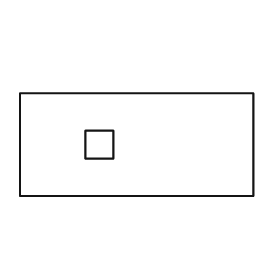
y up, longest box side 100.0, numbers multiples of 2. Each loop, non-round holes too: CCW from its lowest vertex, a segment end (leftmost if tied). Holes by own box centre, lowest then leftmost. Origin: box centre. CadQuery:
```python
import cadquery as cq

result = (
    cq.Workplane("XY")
    .moveTo(-50.0, -22.0)
    .lineTo(50.0, -22.0)
    .lineTo(50.0, 22.0)
    .lineTo(-50.0, 22.0)
    .close()
    .moveTo(-22.0, -6.0)
    .lineTo(-10.0, -6.0)
    .lineTo(-10.0, 6.0)
    .lineTo(-22.0, 6.0)
    .close()
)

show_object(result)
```